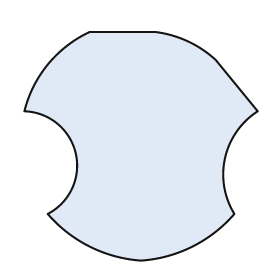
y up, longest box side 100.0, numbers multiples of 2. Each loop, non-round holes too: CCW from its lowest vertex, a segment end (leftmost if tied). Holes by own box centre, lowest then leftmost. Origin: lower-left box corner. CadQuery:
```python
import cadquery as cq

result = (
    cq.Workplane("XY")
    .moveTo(50.0, 0.0)
    .threePointArc((72.0, 6.0), (90.0, 20.0))
    .threePointArc((86.0, 44.0), (100.0, 64.0))
    .lineTo(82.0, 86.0)
    .threePointArc((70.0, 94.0), (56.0, 98.0))
    .lineTo(28.0, 98.0)
    .threePointArc((10.0, 84.0), (0.0, 64.0))
    .threePointArc((22.0, 46.0), (10.0, 20.0))
    .threePointArc((28.0, 6.0), (50.0, 0.0))
    .close()
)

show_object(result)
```